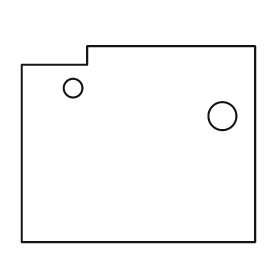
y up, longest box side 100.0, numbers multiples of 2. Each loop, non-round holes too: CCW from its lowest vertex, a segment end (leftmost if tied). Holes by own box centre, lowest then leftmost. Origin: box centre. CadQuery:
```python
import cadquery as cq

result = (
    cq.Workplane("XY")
    .moveTo(-50.0, -42.0)
    .lineTo(50.0, -42.0)
    .lineTo(50.0, 42.0)
    .lineTo(-22.0, 42.0)
    .lineTo(-22.0, 34.0)
    .lineTo(-50.0, 34.0)
    .close()
    .moveTo(36.0, 12.0)
    .circle(6.0)
    .moveTo(-28.0, 24.0)
    .circle(4.0)
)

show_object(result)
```